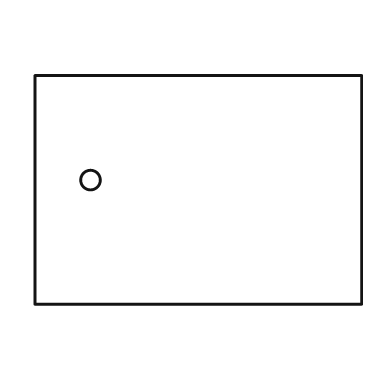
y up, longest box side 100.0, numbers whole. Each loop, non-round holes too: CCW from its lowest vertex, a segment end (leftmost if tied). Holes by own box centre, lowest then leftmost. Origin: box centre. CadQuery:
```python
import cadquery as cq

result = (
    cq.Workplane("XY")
    .moveTo(-50.0, -35.0)
    .lineTo(50.0, -35.0)
    .lineTo(50.0, 35.0)
    .lineTo(-50.0, 35.0)
    .close()
    .moveTo(-33.0, 3.0)
    .circle(3.0)
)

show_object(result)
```